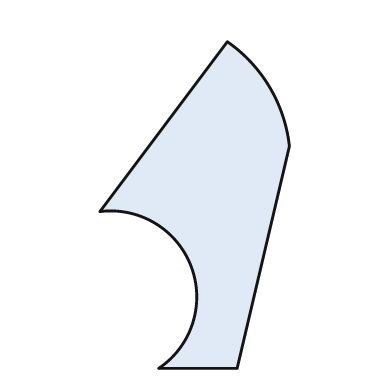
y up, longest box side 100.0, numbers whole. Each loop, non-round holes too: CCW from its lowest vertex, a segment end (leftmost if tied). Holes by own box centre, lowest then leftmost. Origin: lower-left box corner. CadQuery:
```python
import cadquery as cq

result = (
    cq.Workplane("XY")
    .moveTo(18.0, 0.0)
    .lineTo(42.0, 0.0)
    .lineTo(58.0, 68.0)
    .threePointArc((52.0, 86.0), (39.0, 100.0))
    .lineTo(0.0, 48.0)
    .threePointArc((28.0, 31.0), (18.0, 0.0))
    .close()
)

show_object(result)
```